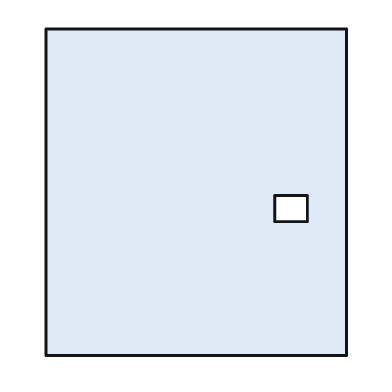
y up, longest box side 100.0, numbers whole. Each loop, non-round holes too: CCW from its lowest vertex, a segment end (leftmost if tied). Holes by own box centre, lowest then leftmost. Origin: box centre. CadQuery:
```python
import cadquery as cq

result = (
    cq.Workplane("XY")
    .moveTo(-46.0, -50.0)
    .lineTo(46.0, -50.0)
    .lineTo(46.0, 50.0)
    .lineTo(-46.0, 50.0)
    .close()
    .moveTo(24.0, -9.0)
    .lineTo(34.0, -9.0)
    .lineTo(34.0, -1.0)
    .lineTo(24.0, -1.0)
    .close()
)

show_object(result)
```